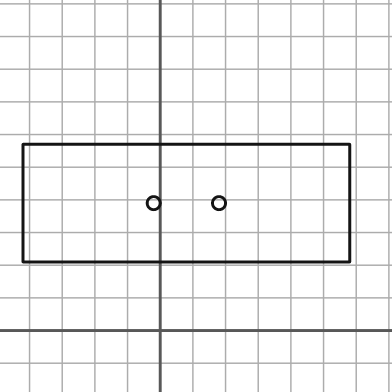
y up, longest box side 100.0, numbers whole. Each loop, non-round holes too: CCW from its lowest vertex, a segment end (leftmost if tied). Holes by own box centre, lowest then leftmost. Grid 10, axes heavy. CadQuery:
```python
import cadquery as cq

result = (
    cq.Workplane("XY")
    .moveTo(-42.0, 21.0)
    .lineTo(58.0, 21.0)
    .lineTo(58.0, 57.0)
    .lineTo(-42.0, 57.0)
    .close()
    .moveTo(-2.0, 39.0)
    .circle(2.0)
    .moveTo(18.0, 39.0)
    .circle(2.0)
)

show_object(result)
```